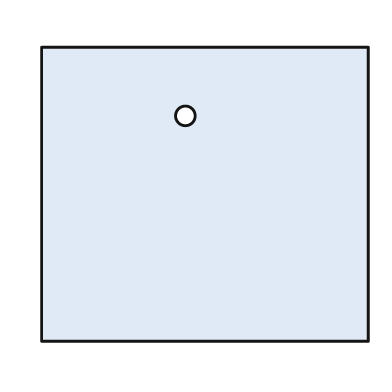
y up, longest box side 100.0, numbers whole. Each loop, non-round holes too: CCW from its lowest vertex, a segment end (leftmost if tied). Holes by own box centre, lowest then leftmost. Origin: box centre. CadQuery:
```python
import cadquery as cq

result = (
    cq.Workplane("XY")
    .moveTo(-50.0, -45.0)
    .lineTo(50.0, -45.0)
    .lineTo(50.0, 45.0)
    .lineTo(-50.0, 45.0)
    .close()
    .moveTo(-6.0, 24.0)
    .circle(3.0)
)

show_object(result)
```